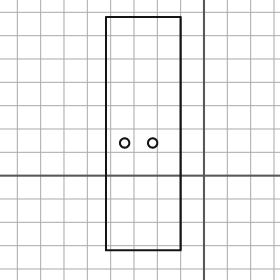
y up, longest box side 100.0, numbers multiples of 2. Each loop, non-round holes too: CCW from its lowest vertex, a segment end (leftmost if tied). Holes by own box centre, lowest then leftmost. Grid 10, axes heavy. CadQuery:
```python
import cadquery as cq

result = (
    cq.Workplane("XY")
    .moveTo(-42.0, -32.0)
    .lineTo(-10.0, -32.0)
    .lineTo(-10.0, 68.0)
    .lineTo(-42.0, 68.0)
    .close()
    .moveTo(-34.0, 14.0)
    .circle(2.0)
    .moveTo(-22.0, 14.0)
    .circle(2.0)
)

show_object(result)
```